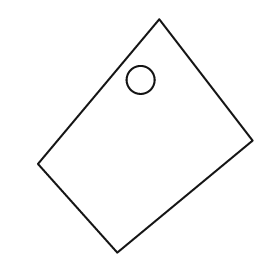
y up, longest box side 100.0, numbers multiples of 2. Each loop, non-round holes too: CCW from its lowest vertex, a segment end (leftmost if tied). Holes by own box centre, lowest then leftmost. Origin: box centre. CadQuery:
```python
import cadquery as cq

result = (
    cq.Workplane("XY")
    .moveTo(-12.0, -50.0)
    .lineTo(46.0, -2.0)
    .lineTo(6.0, 50.0)
    .lineTo(-46.0, -12.0)
    .close()
    .moveTo(-2.0, 24.0)
    .circle(6.0)
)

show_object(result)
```